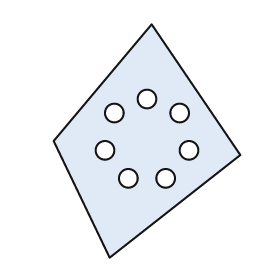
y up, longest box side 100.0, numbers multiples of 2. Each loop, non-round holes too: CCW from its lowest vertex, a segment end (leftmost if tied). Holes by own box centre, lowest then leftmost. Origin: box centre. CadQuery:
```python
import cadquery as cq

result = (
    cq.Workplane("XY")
    .moveTo(-16.0, -50.0)
    .lineTo(40.0, -6.0)
    .lineTo(2.0, 50.0)
    .lineTo(-40.0, 0.0)
    .close()
    .moveTo(-8.0, -16.0)
    .circle(4.0)
    .moveTo(8.0, -16.0)
    .circle(4.0)
    .moveTo(-18.0, -4.0)
    .circle(4.0)
    .moveTo(18.0, -4.0)
    .circle(4.0)
    .moveTo(-14.0, 12.0)
    .circle(4.0)
    .moveTo(14.0, 12.0)
    .circle(4.0)
    .moveTo(0.0, 18.0)
    .circle(4.0)
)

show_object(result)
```